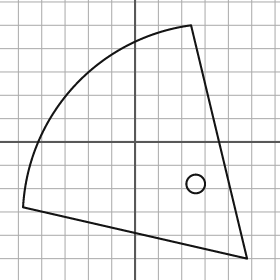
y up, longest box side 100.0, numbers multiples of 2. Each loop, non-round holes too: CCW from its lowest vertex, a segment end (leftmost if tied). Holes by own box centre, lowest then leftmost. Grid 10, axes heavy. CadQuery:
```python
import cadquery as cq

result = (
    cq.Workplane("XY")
    .moveTo(48.0, -50.0)
    .lineTo(24.0, 50.0)
    .threePointArc((-26.0, 24.0), (-48.0, -28.0))
    .close()
    .moveTo(26.0, -18.0)
    .circle(4.0)
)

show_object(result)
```